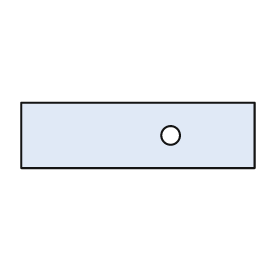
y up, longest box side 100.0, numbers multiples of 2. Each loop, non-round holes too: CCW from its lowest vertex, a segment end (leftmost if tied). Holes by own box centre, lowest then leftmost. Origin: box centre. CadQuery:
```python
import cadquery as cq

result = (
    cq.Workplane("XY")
    .moveTo(-50.0, -14.0)
    .lineTo(50.0, -14.0)
    .lineTo(50.0, 14.0)
    .lineTo(-50.0, 14.0)
    .close()
    .moveTo(14.0, 0.0)
    .circle(4.0)
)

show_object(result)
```